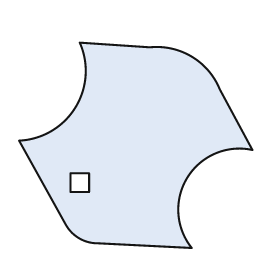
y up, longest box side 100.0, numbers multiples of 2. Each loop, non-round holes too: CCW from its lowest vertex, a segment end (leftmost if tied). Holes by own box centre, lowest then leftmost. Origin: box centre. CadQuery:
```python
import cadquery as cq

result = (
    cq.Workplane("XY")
    .moveTo(24.0, -44.0)
    .threePointArc((22.0, -14.0), (50.0, -2.0))
    .lineTo(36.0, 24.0)
    .threePointArc((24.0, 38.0), (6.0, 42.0))
    .lineTo(-24.0, 44.0)
    .threePointArc((-26.0, 16.0), (-50.0, 2.0))
    .lineTo(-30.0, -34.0)
    .threePointArc((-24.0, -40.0), (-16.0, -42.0))
    .close()
    .moveTo(-28.0, -20.0)
    .lineTo(-20.0, -20.0)
    .lineTo(-20.0, -12.0)
    .lineTo(-28.0, -12.0)
    .close()
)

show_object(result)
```